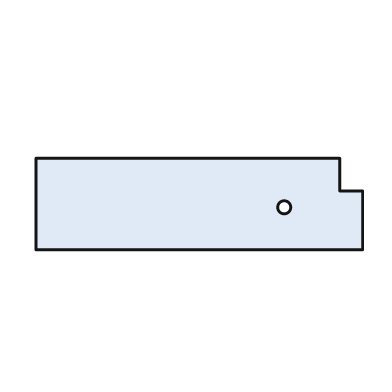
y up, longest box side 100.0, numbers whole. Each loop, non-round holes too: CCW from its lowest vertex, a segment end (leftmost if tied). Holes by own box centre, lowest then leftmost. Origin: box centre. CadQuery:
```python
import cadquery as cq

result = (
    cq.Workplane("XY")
    .moveTo(-50.0, -14.0)
    .lineTo(50.0, -14.0)
    .lineTo(50.0, 4.0)
    .lineTo(43.0, 4.0)
    .lineTo(43.0, 14.0)
    .lineTo(-50.0, 14.0)
    .close()
    .moveTo(26.0, -1.0)
    .circle(2.0)
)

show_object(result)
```